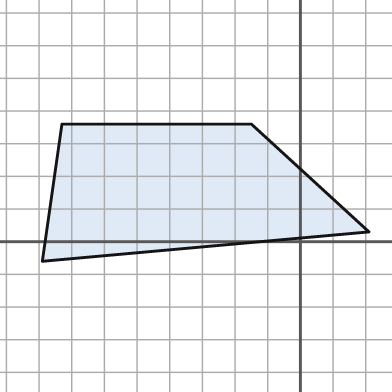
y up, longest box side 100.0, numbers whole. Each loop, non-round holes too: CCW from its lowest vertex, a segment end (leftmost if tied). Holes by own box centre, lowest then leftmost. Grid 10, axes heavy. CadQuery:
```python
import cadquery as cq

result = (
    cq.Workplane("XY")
    .moveTo(-79.0, -6.0)
    .lineTo(21.0, 3.0)
    .lineTo(-15.0, 36.0)
    .lineTo(-73.0, 36.0)
    .close()
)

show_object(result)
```